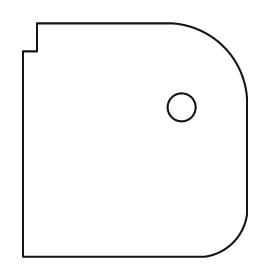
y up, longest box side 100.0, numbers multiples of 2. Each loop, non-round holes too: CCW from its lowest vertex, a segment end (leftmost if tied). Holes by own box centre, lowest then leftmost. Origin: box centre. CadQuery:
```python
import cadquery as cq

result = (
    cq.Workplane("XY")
    .moveTo(-48.0, -50.0)
    .lineTo(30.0, -50.0)
    .threePointArc((42.0, -44.0), (48.0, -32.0))
    .lineTo(48.0, 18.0)
    .threePointArc((38.0, 40.0), (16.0, 50.0))
    .lineTo(-42.0, 50.0)
    .lineTo(-42.0, 38.0)
    .lineTo(-48.0, 38.0)
    .close()
    .moveTo(20.0, 14.0)
    .circle(6.0)
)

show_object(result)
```